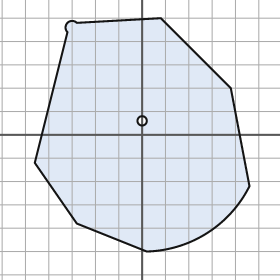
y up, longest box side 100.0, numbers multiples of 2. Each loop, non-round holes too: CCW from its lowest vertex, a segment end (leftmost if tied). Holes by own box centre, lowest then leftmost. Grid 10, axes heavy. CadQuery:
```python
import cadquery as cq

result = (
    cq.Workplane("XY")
    .moveTo(2.0, -50.0)
    .threePointArc((28.0, -42.0), (46.0, -22.0))
    .lineTo(38.0, 20.0)
    .lineTo(8.0, 50.0)
    .lineTo(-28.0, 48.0)
    .threePointArc((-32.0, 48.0), (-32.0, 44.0))
    .lineTo(-46.0, -12.0)
    .lineTo(-28.0, -38.0)
    .close()
    .moveTo(0.0, 6.0)
    .circle(2.0)
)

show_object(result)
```